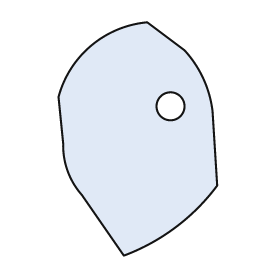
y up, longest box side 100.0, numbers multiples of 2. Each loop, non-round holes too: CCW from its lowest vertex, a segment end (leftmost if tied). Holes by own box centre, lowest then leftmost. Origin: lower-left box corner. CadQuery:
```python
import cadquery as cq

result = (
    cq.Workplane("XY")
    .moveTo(28.0, 0.0)
    .threePointArc((50.0, 12.0), (68.0, 30.0))
    .lineTo(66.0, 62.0)
    .threePointArc((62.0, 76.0), (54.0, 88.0))
    .lineTo(38.0, 100.0)
    .threePointArc((14.0, 90.0), (0.0, 68.0))
    .lineTo(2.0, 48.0)
    .threePointArc((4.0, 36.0), (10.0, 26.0))
    .close()
    .moveTo(48.0, 64.0)
    .circle(6.0)
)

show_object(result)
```